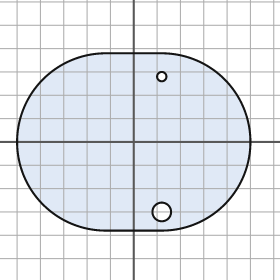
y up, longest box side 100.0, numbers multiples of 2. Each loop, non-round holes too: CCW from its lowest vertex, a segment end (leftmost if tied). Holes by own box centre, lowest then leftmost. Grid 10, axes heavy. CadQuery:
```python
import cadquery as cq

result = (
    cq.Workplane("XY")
    .moveTo(-12.0, -38.0)
    .lineTo(12.0, -38.0)
    .threePointArc((50.0, 0.0), (12.0, 38.0))
    .lineTo(-12.0, 38.0)
    .threePointArc((-50.0, 0.0), (-12.0, -38.0))
    .close()
    .moveTo(12.0, -30.0)
    .circle(4.0)
    .moveTo(12.0, 28.0)
    .circle(2.0)
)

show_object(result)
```